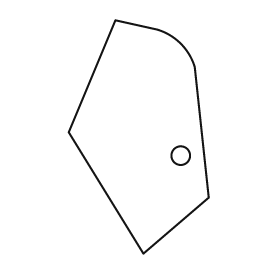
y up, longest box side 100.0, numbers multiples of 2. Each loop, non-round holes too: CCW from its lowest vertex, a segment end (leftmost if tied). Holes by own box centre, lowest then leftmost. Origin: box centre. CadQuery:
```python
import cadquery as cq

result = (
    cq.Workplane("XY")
    .moveTo(2.0, -50.0)
    .lineTo(30.0, -26.0)
    .lineTo(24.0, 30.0)
    .threePointArc((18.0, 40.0), (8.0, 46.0))
    .lineTo(-10.0, 50.0)
    .lineTo(-30.0, 2.0)
    .close()
    .moveTo(18.0, -8.0)
    .circle(4.0)
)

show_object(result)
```